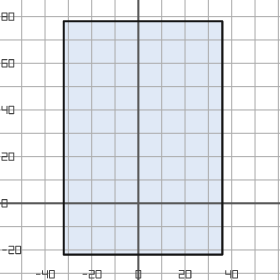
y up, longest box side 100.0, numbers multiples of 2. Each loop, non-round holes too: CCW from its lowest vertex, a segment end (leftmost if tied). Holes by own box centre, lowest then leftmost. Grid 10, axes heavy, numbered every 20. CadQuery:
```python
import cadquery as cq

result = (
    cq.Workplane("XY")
    .moveTo(-32.0, -22.0)
    .lineTo(36.0, -22.0)
    .lineTo(36.0, 78.0)
    .lineTo(-32.0, 78.0)
    .close()
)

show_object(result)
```